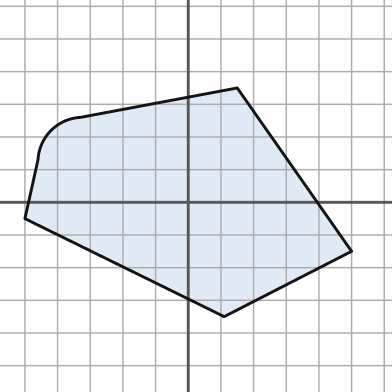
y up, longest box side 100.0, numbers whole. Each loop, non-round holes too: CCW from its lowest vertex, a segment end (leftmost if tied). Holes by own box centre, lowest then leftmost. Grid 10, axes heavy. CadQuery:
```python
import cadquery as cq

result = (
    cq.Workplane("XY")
    .moveTo(11.0, -35.0)
    .lineTo(50.0, -15.0)
    .lineTo(15.0, 35.0)
    .lineTo(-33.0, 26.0)
    .threePointArc((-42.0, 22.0), (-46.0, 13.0))
    .lineTo(-50.0, -5.0)
    .close()
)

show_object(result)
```